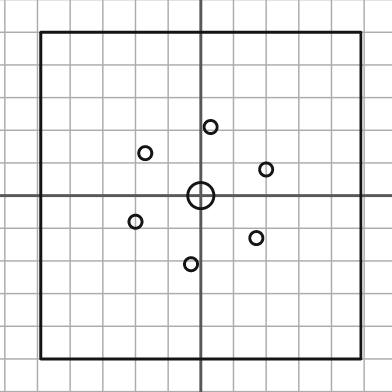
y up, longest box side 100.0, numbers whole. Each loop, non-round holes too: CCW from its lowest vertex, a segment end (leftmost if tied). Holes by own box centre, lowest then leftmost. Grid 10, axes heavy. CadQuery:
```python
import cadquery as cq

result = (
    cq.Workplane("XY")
    .moveTo(-49.0, -50.0)
    .lineTo(49.0, -50.0)
    .lineTo(49.0, 50.0)
    .lineTo(-49.0, 50.0)
    .close()
    .moveTo(-3.0, -21.0)
    .circle(2.0)
    .moveTo(17.0, -13.0)
    .circle(2.0)
    .moveTo(-20.0, -8.0)
    .circle(2.0)
    .moveTo(0.0, 0.0)
    .circle(4.0)
    .moveTo(20.0, 8.0)
    .circle(2.0)
    .moveTo(-17.0, 13.0)
    .circle(2.0)
    .moveTo(3.0, 21.0)
    .circle(2.0)
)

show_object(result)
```